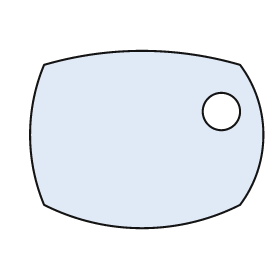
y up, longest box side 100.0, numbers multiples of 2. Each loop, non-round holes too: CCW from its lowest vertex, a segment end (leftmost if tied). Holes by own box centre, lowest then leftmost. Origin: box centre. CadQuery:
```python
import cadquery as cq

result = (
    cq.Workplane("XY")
    .moveTo(-44.0, -28.0)
    .threePointArc((-2.0, -38.0), (40.0, -28.0))
    .threePointArc((50.0, 2.0), (40.0, 32.0))
    .threePointArc((-2.0, 38.0), (-44.0, 32.0))
    .threePointArc((-50.0, 2.0), (-44.0, -28.0))
    .close()
    .moveTo(32.0, 12.0)
    .circle(8.0)
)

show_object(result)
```